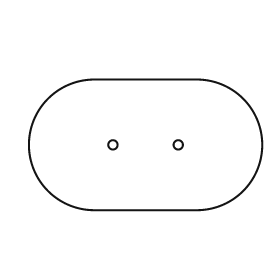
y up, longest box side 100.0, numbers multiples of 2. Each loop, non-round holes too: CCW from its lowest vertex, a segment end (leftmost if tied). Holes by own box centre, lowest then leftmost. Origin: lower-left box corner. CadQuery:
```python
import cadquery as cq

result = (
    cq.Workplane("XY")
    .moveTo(28.0, 0.0)
    .lineTo(72.0, 0.0)
    .threePointArc((100.0, 28.0), (72.0, 56.0))
    .lineTo(28.0, 56.0)
    .threePointArc((0.0, 28.0), (28.0, 0.0))
    .close()
    .moveTo(36.0, 28.0)
    .circle(2.0)
    .moveTo(64.0, 28.0)
    .circle(2.0)
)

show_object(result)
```